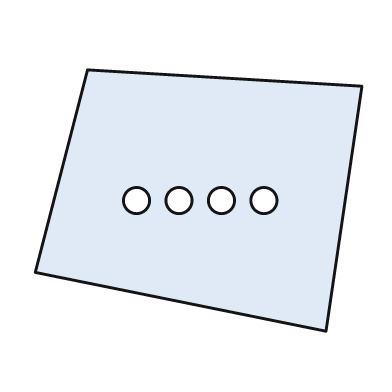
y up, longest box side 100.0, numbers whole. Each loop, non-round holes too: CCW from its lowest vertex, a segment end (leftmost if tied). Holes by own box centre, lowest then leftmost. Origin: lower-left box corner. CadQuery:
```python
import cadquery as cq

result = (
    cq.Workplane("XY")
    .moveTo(89.0, 0.0)
    .lineTo(100.0, 75.0)
    .lineTo(16.0, 80.0)
    .lineTo(0.0, 18.0)
    .close()
    .moveTo(31.0, 40.0)
    .circle(4.0)
    .moveTo(44.0, 40.0)
    .circle(4.0)
    .moveTo(57.0, 40.0)
    .circle(4.0)
    .moveTo(70.0, 40.0)
    .circle(4.0)
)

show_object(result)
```